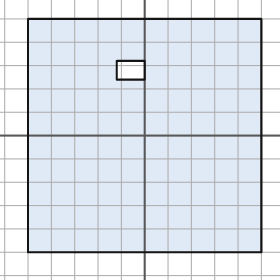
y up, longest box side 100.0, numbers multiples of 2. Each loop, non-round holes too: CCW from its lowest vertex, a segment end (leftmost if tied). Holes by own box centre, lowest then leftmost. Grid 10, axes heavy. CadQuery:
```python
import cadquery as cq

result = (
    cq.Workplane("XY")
    .moveTo(-50.0, -50.0)
    .lineTo(50.0, -50.0)
    .lineTo(50.0, 50.0)
    .lineTo(-50.0, 50.0)
    .close()
    .moveTo(-12.0, 24.0)
    .lineTo(0.0, 24.0)
    .lineTo(0.0, 32.0)
    .lineTo(-12.0, 32.0)
    .close()
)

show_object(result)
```